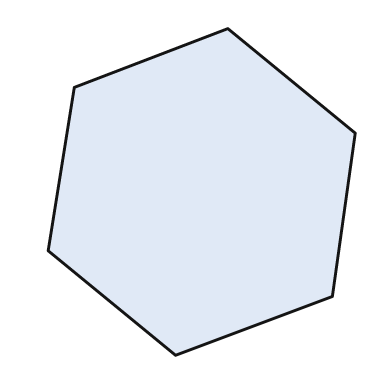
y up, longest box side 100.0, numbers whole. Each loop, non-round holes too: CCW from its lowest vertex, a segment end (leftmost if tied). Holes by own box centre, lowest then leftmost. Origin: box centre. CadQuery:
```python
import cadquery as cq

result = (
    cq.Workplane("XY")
    .moveTo(-8.0, -50.0)
    .lineTo(40.0, -32.0)
    .lineTo(47.0, 18.0)
    .lineTo(8.0, 50.0)
    .lineTo(-39.0, 32.0)
    .lineTo(-47.0, -18.0)
    .close()
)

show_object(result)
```